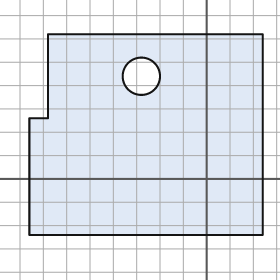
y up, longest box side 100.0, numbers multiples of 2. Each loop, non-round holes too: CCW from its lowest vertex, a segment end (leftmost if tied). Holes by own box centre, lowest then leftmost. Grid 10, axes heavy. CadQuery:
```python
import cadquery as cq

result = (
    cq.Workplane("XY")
    .moveTo(-76.0, -24.0)
    .lineTo(24.0, -24.0)
    .lineTo(24.0, 62.0)
    .lineTo(-68.0, 62.0)
    .lineTo(-68.0, 26.0)
    .lineTo(-76.0, 26.0)
    .close()
    .moveTo(-28.0, 44.0)
    .circle(8.0)
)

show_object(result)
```